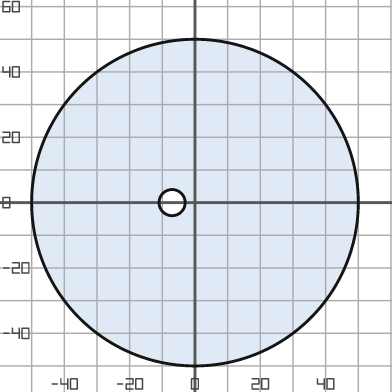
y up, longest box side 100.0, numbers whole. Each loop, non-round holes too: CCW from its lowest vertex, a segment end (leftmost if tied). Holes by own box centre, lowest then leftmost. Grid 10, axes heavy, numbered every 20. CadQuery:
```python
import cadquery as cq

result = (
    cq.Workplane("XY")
    .moveTo(0.0, 0.0)
    .circle(50.0)
    .moveTo(-7.0, 0.0)
    .circle(4.0)
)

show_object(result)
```